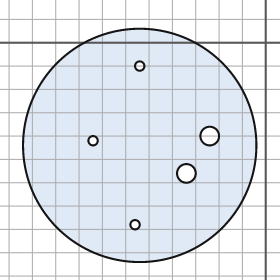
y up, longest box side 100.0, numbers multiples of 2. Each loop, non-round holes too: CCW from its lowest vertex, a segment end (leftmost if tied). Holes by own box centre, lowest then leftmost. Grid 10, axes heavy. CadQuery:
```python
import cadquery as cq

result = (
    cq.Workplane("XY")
    .moveTo(-54.0, -44.0)
    .circle(50.0)
    .moveTo(-56.0, -78.0)
    .circle(2.0)
    .moveTo(-34.0, -56.0)
    .circle(4.0)
    .moveTo(-74.0, -42.0)
    .circle(2.0)
    .moveTo(-24.0, -40.0)
    .circle(4.0)
    .moveTo(-54.0, -10.0)
    .circle(2.0)
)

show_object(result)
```